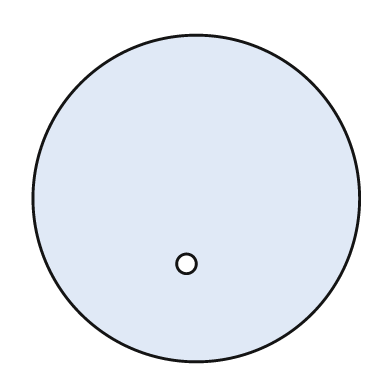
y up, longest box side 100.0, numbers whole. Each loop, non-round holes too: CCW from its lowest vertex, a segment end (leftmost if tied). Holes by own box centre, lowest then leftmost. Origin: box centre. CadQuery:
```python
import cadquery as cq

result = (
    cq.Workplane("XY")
    .moveTo(0.0, 0.0)
    .circle(50.0)
    .moveTo(-3.0, -20.0)
    .circle(3.0)
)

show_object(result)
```